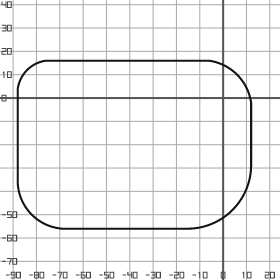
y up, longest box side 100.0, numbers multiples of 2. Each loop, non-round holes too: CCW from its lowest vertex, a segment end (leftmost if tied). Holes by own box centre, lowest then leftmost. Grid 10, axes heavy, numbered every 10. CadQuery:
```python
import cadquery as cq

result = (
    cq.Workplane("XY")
    .moveTo(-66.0, -56.0)
    .lineTo(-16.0, -56.0)
    .threePointArc((4.0, -48.0), (12.0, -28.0))
    .lineTo(12.0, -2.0)
    .threePointArc((6.0, 10.0), (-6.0, 16.0))
    .lineTo(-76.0, 16.0)
    .threePointArc((-84.0, 12.0), (-88.0, 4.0))
    .lineTo(-88.0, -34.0)
    .threePointArc((-82.0, -50.0), (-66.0, -56.0))
    .close()
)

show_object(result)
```